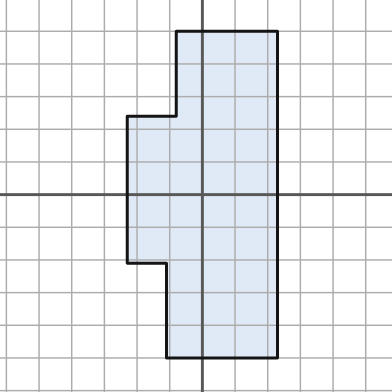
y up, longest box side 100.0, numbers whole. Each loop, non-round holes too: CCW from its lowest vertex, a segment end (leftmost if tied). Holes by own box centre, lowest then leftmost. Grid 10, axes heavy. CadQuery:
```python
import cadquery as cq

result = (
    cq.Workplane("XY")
    .moveTo(-11.0, -50.0)
    .lineTo(23.0, -50.0)
    .lineTo(23.0, 50.0)
    .lineTo(-8.0, 50.0)
    .lineTo(-8.0, 24.0)
    .lineTo(-23.0, 24.0)
    .lineTo(-23.0, -21.0)
    .lineTo(-11.0, -21.0)
    .close()
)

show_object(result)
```